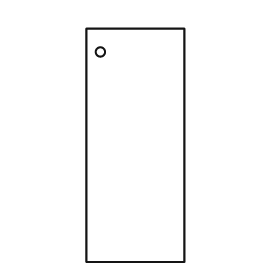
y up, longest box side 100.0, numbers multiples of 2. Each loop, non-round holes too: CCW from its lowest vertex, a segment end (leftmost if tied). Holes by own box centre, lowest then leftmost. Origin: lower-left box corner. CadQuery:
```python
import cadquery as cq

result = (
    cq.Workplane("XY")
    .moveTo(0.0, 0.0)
    .lineTo(42.0, 0.0)
    .lineTo(42.0, 100.0)
    .lineTo(0.0, 100.0)
    .close()
    .moveTo(6.0, 90.0)
    .circle(2.0)
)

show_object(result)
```